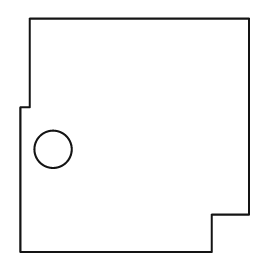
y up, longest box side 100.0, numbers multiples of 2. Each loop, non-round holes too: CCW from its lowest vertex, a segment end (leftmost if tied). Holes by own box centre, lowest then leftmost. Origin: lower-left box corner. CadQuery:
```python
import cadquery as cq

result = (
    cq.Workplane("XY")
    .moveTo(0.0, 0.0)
    .lineTo(82.0, 0.0)
    .lineTo(82.0, 16.0)
    .lineTo(98.0, 16.0)
    .lineTo(98.0, 100.0)
    .lineTo(4.0, 100.0)
    .lineTo(4.0, 62.0)
    .lineTo(0.0, 62.0)
    .close()
    .moveTo(14.0, 44.0)
    .circle(8.0)
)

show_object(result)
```